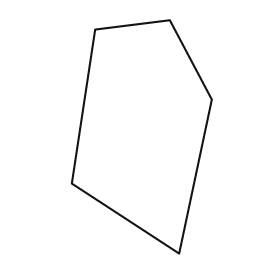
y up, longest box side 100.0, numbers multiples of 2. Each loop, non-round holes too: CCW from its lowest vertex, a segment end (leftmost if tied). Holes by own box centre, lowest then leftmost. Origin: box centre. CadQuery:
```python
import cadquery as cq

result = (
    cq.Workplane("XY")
    .moveTo(16.0, -50.0)
    .lineTo(30.0, 16.0)
    .lineTo(12.0, 50.0)
    .lineTo(-20.0, 46.0)
    .lineTo(-30.0, -20.0)
    .close()
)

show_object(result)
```